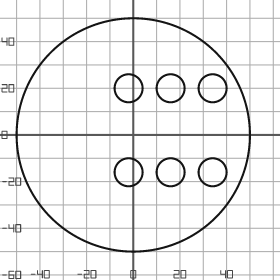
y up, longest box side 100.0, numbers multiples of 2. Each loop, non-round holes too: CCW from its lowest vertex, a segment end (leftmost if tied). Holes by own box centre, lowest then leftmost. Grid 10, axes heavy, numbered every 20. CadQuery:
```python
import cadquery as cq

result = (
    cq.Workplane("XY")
    .moveTo(0.0, 0.0)
    .circle(50.0)
    .moveTo(-2.0, -16.0)
    .circle(6.0)
    .moveTo(16.0, -16.0)
    .circle(6.0)
    .moveTo(34.0, -16.0)
    .circle(6.0)
    .moveTo(-2.0, 20.0)
    .circle(6.0)
    .moveTo(16.0, 20.0)
    .circle(6.0)
    .moveTo(34.0, 20.0)
    .circle(6.0)
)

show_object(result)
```